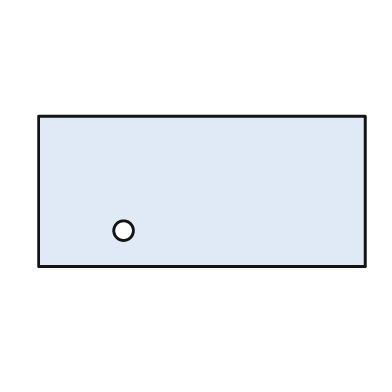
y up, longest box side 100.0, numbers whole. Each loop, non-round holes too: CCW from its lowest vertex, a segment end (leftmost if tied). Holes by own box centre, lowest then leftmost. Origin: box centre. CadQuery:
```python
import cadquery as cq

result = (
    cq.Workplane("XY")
    .moveTo(-50.0, -23.0)
    .lineTo(50.0, -23.0)
    .lineTo(50.0, 23.0)
    .lineTo(-50.0, 23.0)
    .close()
    .moveTo(-24.0, -12.0)
    .circle(3.0)
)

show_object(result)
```